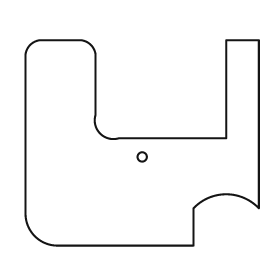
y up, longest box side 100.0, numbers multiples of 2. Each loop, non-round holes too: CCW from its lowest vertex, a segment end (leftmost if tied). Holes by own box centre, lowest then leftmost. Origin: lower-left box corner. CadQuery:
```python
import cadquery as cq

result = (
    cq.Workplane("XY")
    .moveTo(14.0, 0.0)
    .lineTo(72.0, 0.0)
    .lineTo(72.0, 16.0)
    .threePointArc((86.0, 22.0), (100.0, 16.0))
    .lineTo(100.0, 88.0)
    .lineTo(86.0, 88.0)
    .lineTo(86.0, 46.0)
    .lineTo(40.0, 46.0)
    .threePointArc((32.0, 48.0), (30.0, 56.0))
    .lineTo(30.0, 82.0)
    .threePointArc((28.0, 86.0), (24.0, 88.0))
    .lineTo(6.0, 88.0)
    .threePointArc((2.0, 86.0), (0.0, 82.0))
    .lineTo(0.0, 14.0)
    .threePointArc((4.0, 4.0), (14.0, 0.0))
    .close()
    .moveTo(50.0, 38.0)
    .circle(2.0)
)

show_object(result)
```